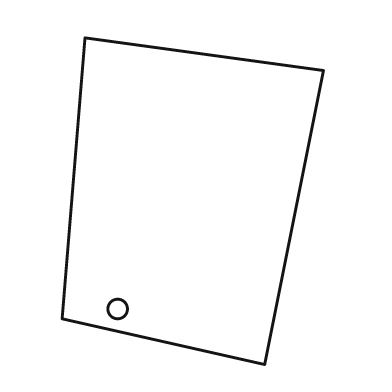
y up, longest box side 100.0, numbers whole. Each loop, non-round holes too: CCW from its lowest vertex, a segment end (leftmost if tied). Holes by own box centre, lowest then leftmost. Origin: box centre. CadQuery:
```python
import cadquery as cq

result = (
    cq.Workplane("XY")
    .moveTo(22.0, -50.0)
    .lineTo(40.0, 40.0)
    .lineTo(-33.0, 50.0)
    .lineTo(-40.0, -36.0)
    .close()
    .moveTo(-23.0, -33.0)
    .circle(3.0)
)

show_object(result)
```